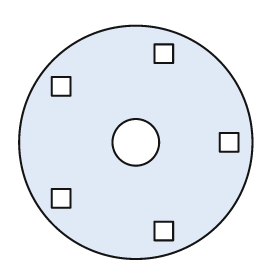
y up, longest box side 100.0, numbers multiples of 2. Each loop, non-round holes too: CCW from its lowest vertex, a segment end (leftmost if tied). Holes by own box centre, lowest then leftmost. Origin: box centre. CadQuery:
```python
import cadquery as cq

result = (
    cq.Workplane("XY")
    .moveTo(0.0, 0.0)
    .circle(50.0)
    .moveTo(8.0, -42.0)
    .lineTo(16.0, -42.0)
    .lineTo(16.0, -34.0)
    .lineTo(8.0, -34.0)
    .close()
    .moveTo(-36.0, -28.0)
    .lineTo(-28.0, -28.0)
    .lineTo(-28.0, -20.0)
    .lineTo(-36.0, -20.0)
    .close()
    .moveTo(0.0, 0.0)
    .circle(10.0)
    .moveTo(36.0, -4.0)
    .lineTo(44.0, -4.0)
    .lineTo(44.0, 4.0)
    .lineTo(36.0, 4.0)
    .close()
    .moveTo(-36.0, 20.0)
    .lineTo(-28.0, 20.0)
    .lineTo(-28.0, 28.0)
    .lineTo(-36.0, 28.0)
    .close()
    .moveTo(8.0, 34.0)
    .lineTo(16.0, 34.0)
    .lineTo(16.0, 42.0)
    .lineTo(8.0, 42.0)
    .close()
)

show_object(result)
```